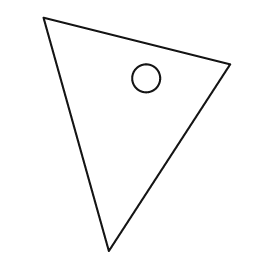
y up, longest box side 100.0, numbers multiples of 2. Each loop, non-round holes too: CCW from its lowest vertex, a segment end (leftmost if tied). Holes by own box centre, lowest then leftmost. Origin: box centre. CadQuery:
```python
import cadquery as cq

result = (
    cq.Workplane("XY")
    .moveTo(-12.0, -50.0)
    .lineTo(40.0, 30.0)
    .lineTo(-40.0, 50.0)
    .close()
    .moveTo(4.0, 24.0)
    .circle(6.0)
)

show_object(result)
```